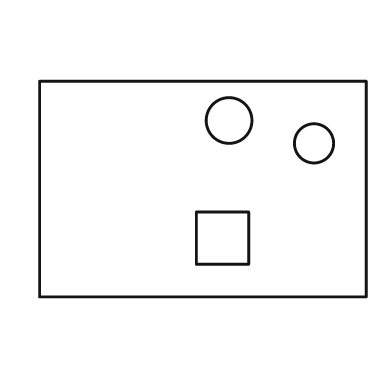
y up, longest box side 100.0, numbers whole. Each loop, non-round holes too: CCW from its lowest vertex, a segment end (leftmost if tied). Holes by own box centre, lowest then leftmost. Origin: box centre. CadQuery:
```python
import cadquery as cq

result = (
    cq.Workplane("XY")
    .moveTo(-50.0, -33.0)
    .lineTo(50.0, -33.0)
    .lineTo(50.0, 33.0)
    .lineTo(-50.0, 33.0)
    .close()
    .moveTo(-2.0, -23.0)
    .lineTo(14.0, -23.0)
    .lineTo(14.0, -7.0)
    .lineTo(-2.0, -7.0)
    .close()
    .moveTo(34.0, 14.0)
    .circle(6.0)
    .moveTo(8.0, 21.0)
    .circle(7.0)
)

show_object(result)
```